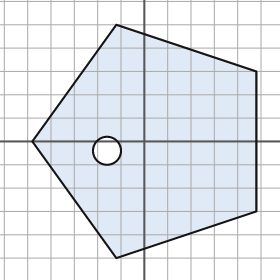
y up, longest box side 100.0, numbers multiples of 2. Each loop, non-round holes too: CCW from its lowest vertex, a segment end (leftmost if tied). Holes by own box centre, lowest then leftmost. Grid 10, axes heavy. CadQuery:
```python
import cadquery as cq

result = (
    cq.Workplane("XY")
    .moveTo(-12.0, -50.0)
    .lineTo(48.0, -30.0)
    .lineTo(48.0, 30.0)
    .lineTo(-12.0, 50.0)
    .lineTo(-48.0, 0.0)
    .close()
    .moveTo(-16.0, -4.0)
    .circle(6.0)
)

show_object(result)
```